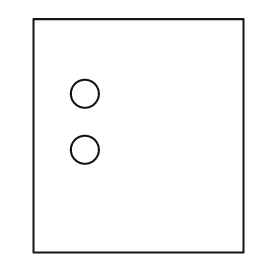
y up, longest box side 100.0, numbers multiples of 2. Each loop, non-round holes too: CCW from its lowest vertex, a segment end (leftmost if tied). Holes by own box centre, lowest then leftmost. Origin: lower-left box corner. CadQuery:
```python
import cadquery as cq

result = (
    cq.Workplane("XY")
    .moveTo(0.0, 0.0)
    .lineTo(90.0, 0.0)
    .lineTo(90.0, 100.0)
    .lineTo(0.0, 100.0)
    .close()
    .moveTo(22.0, 44.0)
    .circle(6.0)
    .moveTo(22.0, 68.0)
    .circle(6.0)
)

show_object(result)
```